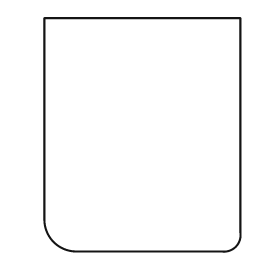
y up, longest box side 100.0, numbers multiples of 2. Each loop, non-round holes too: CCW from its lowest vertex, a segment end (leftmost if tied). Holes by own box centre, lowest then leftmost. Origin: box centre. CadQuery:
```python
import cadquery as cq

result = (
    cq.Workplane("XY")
    .moveTo(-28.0, -50.0)
    .lineTo(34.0, -50.0)
    .threePointArc((40.0, -48.0), (42.0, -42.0))
    .lineTo(42.0, 50.0)
    .lineTo(-42.0, 50.0)
    .lineTo(-42.0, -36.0)
    .threePointArc((-38.0, -46.0), (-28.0, -50.0))
    .close()
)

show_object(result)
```